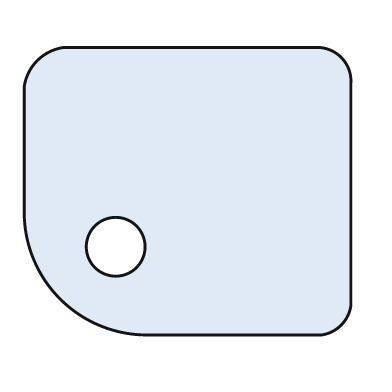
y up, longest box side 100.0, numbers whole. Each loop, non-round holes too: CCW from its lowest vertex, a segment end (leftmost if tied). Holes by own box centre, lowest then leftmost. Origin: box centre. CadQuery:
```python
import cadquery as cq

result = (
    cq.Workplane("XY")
    .moveTo(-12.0, -44.0)
    .lineTo(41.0, -44.0)
    .threePointArc((47.0, -41.0), (50.0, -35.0))
    .lineTo(50.0, 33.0)
    .threePointArc((47.0, 41.0), (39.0, 44.0))
    .lineTo(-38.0, 44.0)
    .threePointArc((-46.0, 40.0), (-50.0, 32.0))
    .lineTo(-50.0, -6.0)
    .threePointArc((-39.0, -33.0), (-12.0, -44.0))
    .close()
    .moveTo(-22.0, -17.0)
    .circle(9.0)
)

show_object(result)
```